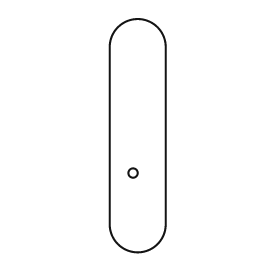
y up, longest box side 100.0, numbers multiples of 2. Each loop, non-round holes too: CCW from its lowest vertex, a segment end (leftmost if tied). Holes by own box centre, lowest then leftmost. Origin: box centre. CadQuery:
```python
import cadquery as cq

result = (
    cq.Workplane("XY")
    .moveTo(-12.0, -38.0)
    .threePointArc((0.0, -50.0), (12.0, -38.0))
    .lineTo(12.0, 38.0)
    .threePointArc((0.0, 50.0), (-12.0, 38.0))
    .close()
    .moveTo(-2.0, -16.0)
    .circle(2.0)
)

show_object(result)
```